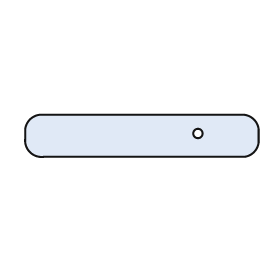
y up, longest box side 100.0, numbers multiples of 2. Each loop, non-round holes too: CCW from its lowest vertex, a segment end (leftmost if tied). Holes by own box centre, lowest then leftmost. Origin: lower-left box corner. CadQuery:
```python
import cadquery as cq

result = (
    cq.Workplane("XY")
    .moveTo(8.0, 0.0)
    .lineTo(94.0, 0.0)
    .threePointArc((98.0, 2.0), (100.0, 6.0))
    .lineTo(100.0, 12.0)
    .threePointArc((98.0, 16.0), (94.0, 18.0))
    .lineTo(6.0, 18.0)
    .threePointArc((2.0, 16.0), (0.0, 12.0))
    .lineTo(0.0, 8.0)
    .threePointArc((2.0, 2.0), (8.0, 0.0))
    .close()
    .moveTo(74.0, 10.0)
    .circle(2.0)
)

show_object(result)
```